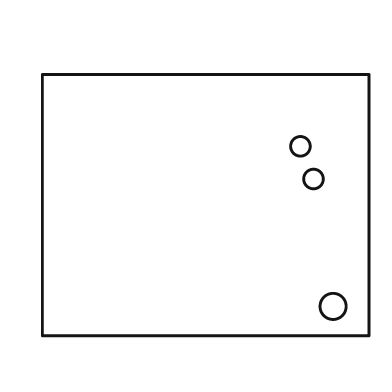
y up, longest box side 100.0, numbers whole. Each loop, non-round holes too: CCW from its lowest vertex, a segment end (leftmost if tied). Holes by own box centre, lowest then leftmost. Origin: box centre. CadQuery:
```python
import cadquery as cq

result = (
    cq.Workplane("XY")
    .moveTo(-50.0, -40.0)
    .lineTo(50.0, -40.0)
    .lineTo(50.0, 40.0)
    .lineTo(-50.0, 40.0)
    .close()
    .moveTo(39.0, -31.0)
    .circle(4.0)
    .moveTo(33.0, 8.0)
    .circle(3.0)
    .moveTo(29.0, 18.0)
    .circle(3.0)
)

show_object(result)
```